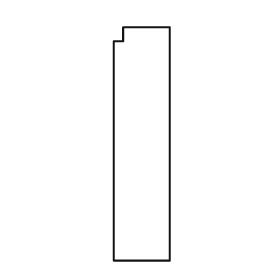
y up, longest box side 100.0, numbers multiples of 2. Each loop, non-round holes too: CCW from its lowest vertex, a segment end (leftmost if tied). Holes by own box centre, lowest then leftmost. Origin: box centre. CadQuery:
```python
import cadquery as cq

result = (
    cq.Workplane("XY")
    .moveTo(-12.0, -50.0)
    .lineTo(12.0, -50.0)
    .lineTo(12.0, 50.0)
    .lineTo(-8.0, 50.0)
    .lineTo(-8.0, 44.0)
    .lineTo(-12.0, 44.0)
    .close()
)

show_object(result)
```